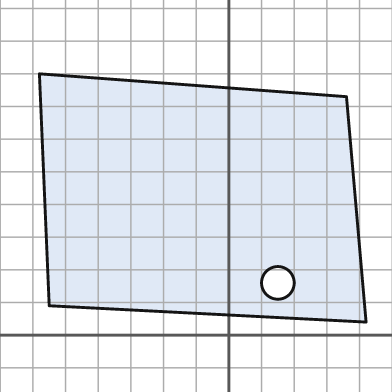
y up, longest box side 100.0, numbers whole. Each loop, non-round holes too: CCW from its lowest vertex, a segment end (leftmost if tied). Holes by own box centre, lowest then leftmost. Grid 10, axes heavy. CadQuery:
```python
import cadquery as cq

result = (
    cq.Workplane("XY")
    .moveTo(42.0, 4.0)
    .lineTo(36.0, 73.0)
    .lineTo(-58.0, 80.0)
    .lineTo(-55.0, 9.0)
    .close()
    .moveTo(15.0, 16.0)
    .circle(5.0)
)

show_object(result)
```